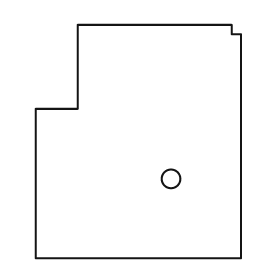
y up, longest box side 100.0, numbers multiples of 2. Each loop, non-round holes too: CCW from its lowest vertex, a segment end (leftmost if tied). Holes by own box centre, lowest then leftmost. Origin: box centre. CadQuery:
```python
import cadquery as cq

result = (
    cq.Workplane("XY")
    .moveTo(-44.0, -50.0)
    .lineTo(44.0, -50.0)
    .lineTo(44.0, 46.0)
    .lineTo(40.0, 46.0)
    .lineTo(40.0, 50.0)
    .lineTo(-26.0, 50.0)
    .lineTo(-26.0, 14.0)
    .lineTo(-44.0, 14.0)
    .close()
    .moveTo(14.0, -16.0)
    .circle(4.0)
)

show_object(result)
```